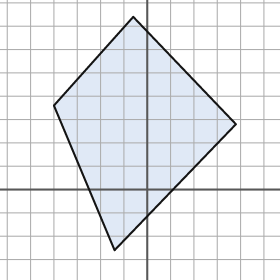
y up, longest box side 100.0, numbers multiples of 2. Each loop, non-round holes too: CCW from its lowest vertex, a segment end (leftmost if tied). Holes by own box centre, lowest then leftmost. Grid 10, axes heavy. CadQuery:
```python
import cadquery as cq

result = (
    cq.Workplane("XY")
    .moveTo(-14.0, -26.0)
    .lineTo(38.0, 28.0)
    .lineTo(-6.0, 74.0)
    .lineTo(-40.0, 36.0)
    .close()
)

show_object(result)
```